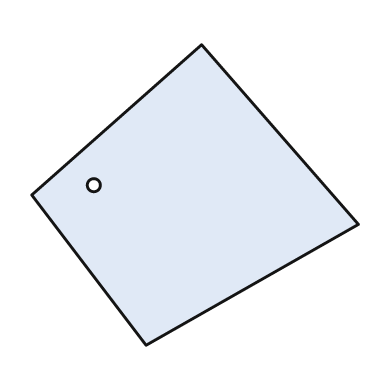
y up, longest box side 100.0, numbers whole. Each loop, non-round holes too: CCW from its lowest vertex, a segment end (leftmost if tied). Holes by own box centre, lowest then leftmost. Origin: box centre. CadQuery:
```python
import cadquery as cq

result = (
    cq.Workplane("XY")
    .moveTo(-15.0, -46.0)
    .lineTo(50.0, -9.0)
    .lineTo(2.0, 46.0)
    .lineTo(-50.0, 0.0)
    .close()
    .moveTo(-31.0, 3.0)
    .circle(2.0)
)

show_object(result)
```